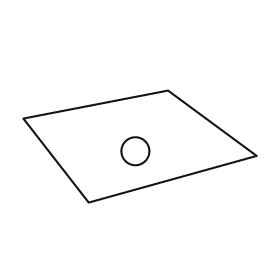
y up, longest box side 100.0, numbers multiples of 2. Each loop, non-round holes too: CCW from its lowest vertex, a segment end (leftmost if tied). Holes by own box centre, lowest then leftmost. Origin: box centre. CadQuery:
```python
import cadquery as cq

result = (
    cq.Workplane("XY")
    .moveTo(-22.0, -24.0)
    .lineTo(50.0, -4.0)
    .lineTo(12.0, 24.0)
    .lineTo(-50.0, 12.0)
    .close()
    .moveTo(-2.0, -2.0)
    .circle(6.0)
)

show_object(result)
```